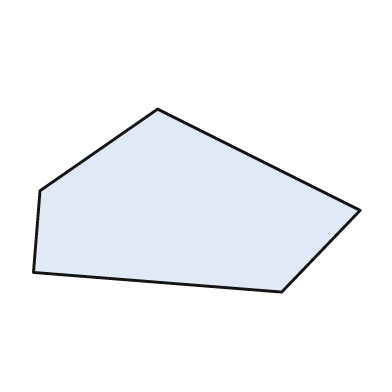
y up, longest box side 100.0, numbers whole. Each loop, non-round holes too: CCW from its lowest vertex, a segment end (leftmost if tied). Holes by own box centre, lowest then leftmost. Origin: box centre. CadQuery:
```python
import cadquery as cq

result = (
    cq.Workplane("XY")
    .moveTo(26.0, -28.0)
    .lineTo(50.0, -3.0)
    .lineTo(-12.0, 28.0)
    .lineTo(-48.0, 3.0)
    .lineTo(-50.0, -22.0)
    .close()
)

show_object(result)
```